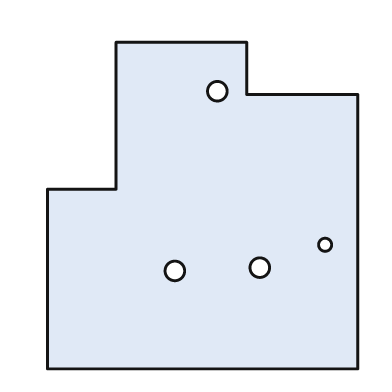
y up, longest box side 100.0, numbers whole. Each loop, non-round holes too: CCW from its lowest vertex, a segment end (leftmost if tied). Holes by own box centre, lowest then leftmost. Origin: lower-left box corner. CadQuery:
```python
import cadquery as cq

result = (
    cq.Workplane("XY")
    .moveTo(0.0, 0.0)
    .lineTo(95.0, 0.0)
    .lineTo(95.0, 84.0)
    .lineTo(61.0, 84.0)
    .lineTo(61.0, 100.0)
    .lineTo(21.0, 100.0)
    .lineTo(21.0, 55.0)
    .lineTo(0.0, 55.0)
    .close()
    .moveTo(39.0, 30.0)
    .circle(3.0)
    .moveTo(65.0, 31.0)
    .circle(3.0)
    .moveTo(85.0, 38.0)
    .circle(2.0)
    .moveTo(52.0, 85.0)
    .circle(3.0)
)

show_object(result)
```